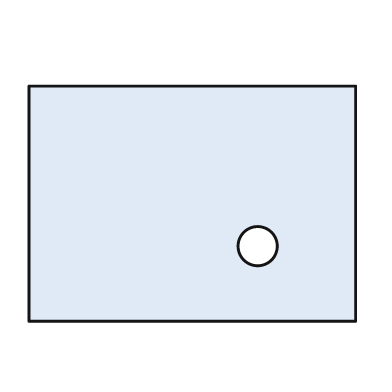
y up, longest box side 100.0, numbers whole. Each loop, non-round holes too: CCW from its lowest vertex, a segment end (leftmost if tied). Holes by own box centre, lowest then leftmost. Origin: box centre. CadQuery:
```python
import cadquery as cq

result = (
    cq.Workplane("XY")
    .moveTo(-50.0, -36.0)
    .lineTo(50.0, -36.0)
    .lineTo(50.0, 36.0)
    .lineTo(-50.0, 36.0)
    .close()
    .moveTo(20.0, -13.0)
    .circle(6.0)
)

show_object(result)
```